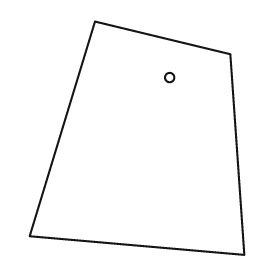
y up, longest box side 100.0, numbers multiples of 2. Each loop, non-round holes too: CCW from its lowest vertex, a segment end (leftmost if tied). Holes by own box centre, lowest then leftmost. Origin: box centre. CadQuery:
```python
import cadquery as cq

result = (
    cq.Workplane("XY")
    .moveTo(46.0, -50.0)
    .lineTo(40.0, 36.0)
    .lineTo(-18.0, 50.0)
    .lineTo(-46.0, -42.0)
    .close()
    .moveTo(14.0, 26.0)
    .circle(2.0)
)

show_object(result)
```